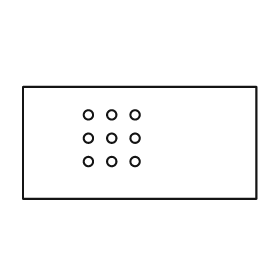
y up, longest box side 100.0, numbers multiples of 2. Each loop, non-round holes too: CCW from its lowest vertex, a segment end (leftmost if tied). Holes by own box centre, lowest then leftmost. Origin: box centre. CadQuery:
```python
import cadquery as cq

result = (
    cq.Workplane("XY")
    .moveTo(-50.0, -24.0)
    .lineTo(50.0, -24.0)
    .lineTo(50.0, 24.0)
    .lineTo(-50.0, 24.0)
    .close()
    .moveTo(-22.0, -8.0)
    .circle(2.0)
    .moveTo(-12.0, -8.0)
    .circle(2.0)
    .moveTo(-2.0, -8.0)
    .circle(2.0)
    .moveTo(-22.0, 2.0)
    .circle(2.0)
    .moveTo(-12.0, 2.0)
    .circle(2.0)
    .moveTo(-2.0, 2.0)
    .circle(2.0)
    .moveTo(-22.0, 12.0)
    .circle(2.0)
    .moveTo(-12.0, 12.0)
    .circle(2.0)
    .moveTo(-2.0, 12.0)
    .circle(2.0)
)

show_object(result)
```